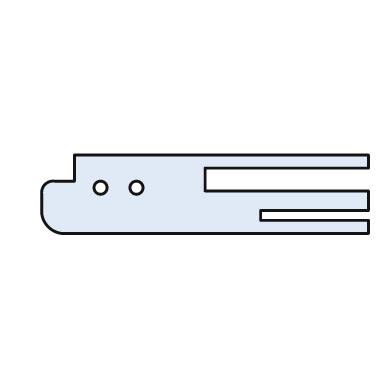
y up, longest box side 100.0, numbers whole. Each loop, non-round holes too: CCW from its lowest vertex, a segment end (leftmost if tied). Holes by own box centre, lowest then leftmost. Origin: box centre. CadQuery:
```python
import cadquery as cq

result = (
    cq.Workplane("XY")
    .moveTo(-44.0, -12.0)
    .lineTo(50.0, -12.0)
    .lineTo(50.0, -8.0)
    .lineTo(17.0, -8.0)
    .lineTo(17.0, -5.0)
    .lineTo(50.0, -5.0)
    .lineTo(50.0, 1.0)
    .lineTo(0.0, 1.0)
    .lineTo(0.0, 8.0)
    .lineTo(50.0, 8.0)
    .lineTo(50.0, 12.0)
    .lineTo(-40.0, 12.0)
    .lineTo(-40.0, 4.0)
    .lineTo(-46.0, 4.0)
    .threePointArc((-49.0, 3.0), (-50.0, 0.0))
    .lineTo(-50.0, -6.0)
    .threePointArc((-48.0, -10.0), (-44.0, -12.0))
    .close()
    .moveTo(-32.0, 2.0)
    .circle(2.0)
    .moveTo(-21.0, 2.0)
    .circle(2.0)
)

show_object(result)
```